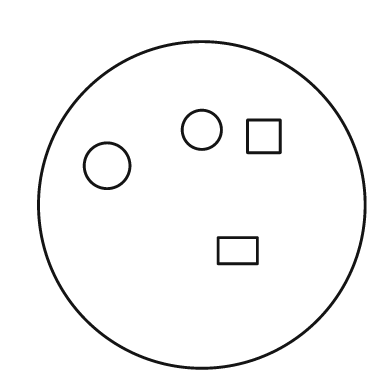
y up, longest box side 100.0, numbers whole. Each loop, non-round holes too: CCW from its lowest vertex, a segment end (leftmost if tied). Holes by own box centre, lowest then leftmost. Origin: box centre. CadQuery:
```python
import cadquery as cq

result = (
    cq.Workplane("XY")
    .moveTo(0.0, 0.0)
    .circle(50.0)
    .moveTo(5.0, -18.0)
    .lineTo(17.0, -18.0)
    .lineTo(17.0, -10.0)
    .lineTo(5.0, -10.0)
    .close()
    .moveTo(-29.0, 12.0)
    .circle(7.0)
    .moveTo(14.0, 16.0)
    .lineTo(24.0, 16.0)
    .lineTo(24.0, 26.0)
    .lineTo(14.0, 26.0)
    .close()
    .moveTo(0.0, 23.0)
    .circle(6.0)
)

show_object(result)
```